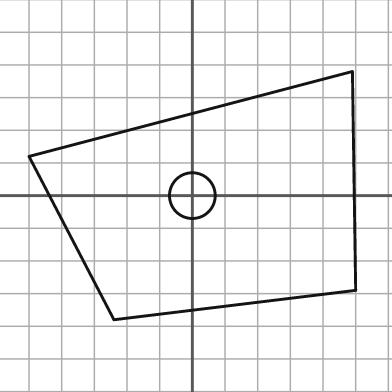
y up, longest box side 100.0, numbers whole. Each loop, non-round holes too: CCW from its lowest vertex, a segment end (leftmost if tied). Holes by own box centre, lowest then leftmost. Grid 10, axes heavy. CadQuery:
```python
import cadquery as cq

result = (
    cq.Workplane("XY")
    .moveTo(-24.0, -38.0)
    .lineTo(50.0, -29.0)
    .lineTo(49.0, 38.0)
    .lineTo(-50.0, 12.0)
    .close()
    .moveTo(0.0, 0.0)
    .circle(7.0)
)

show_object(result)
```